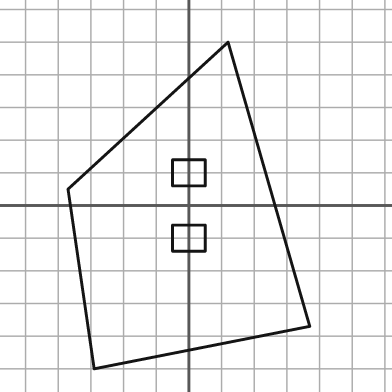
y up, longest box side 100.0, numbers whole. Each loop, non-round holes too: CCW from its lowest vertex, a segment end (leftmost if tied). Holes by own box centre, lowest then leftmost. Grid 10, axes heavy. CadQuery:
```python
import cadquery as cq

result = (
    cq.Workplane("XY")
    .moveTo(-29.0, -50.0)
    .lineTo(37.0, -37.0)
    .lineTo(12.0, 50.0)
    .lineTo(-37.0, 5.0)
    .close()
    .moveTo(-5.0, -14.0)
    .lineTo(5.0, -14.0)
    .lineTo(5.0, -6.0)
    .lineTo(-5.0, -6.0)
    .close()
    .moveTo(-5.0, 6.0)
    .lineTo(5.0, 6.0)
    .lineTo(5.0, 14.0)
    .lineTo(-5.0, 14.0)
    .close()
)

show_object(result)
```